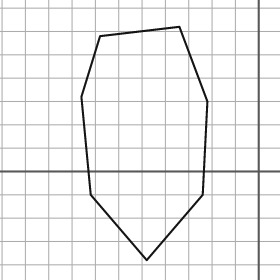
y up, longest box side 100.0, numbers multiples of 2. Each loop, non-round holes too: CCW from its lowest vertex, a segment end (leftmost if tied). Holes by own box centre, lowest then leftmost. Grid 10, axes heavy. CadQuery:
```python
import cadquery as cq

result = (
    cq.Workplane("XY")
    .moveTo(-48.0, -38.0)
    .lineTo(-24.0, -10.0)
    .lineTo(-22.0, 30.0)
    .lineTo(-34.0, 62.0)
    .lineTo(-68.0, 58.0)
    .lineTo(-76.0, 32.0)
    .lineTo(-72.0, -10.0)
    .close()
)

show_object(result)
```